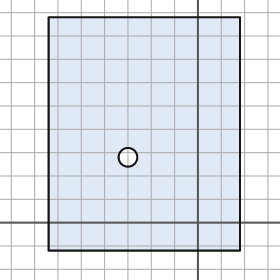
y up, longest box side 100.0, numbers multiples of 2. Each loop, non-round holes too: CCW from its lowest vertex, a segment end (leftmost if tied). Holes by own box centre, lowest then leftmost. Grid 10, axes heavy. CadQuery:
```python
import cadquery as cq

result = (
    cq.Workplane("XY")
    .moveTo(-64.0, -12.0)
    .lineTo(18.0, -12.0)
    .lineTo(18.0, 88.0)
    .lineTo(-64.0, 88.0)
    .close()
    .moveTo(-30.0, 28.0)
    .circle(4.0)
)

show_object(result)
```